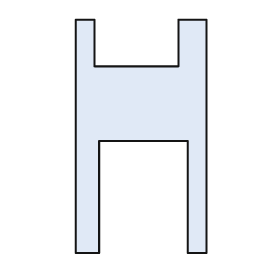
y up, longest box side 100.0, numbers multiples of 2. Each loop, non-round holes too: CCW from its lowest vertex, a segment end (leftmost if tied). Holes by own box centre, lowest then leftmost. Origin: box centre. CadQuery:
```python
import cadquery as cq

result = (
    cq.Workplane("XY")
    .moveTo(-28.0, -50.0)
    .lineTo(-18.0, -50.0)
    .lineTo(-18.0, -2.0)
    .lineTo(20.0, -2.0)
    .lineTo(20.0, -50.0)
    .lineTo(28.0, -50.0)
    .lineTo(28.0, 50.0)
    .lineTo(16.0, 50.0)
    .lineTo(16.0, 30.0)
    .lineTo(-20.0, 30.0)
    .lineTo(-20.0, 50.0)
    .lineTo(-28.0, 50.0)
    .close()
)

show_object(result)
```